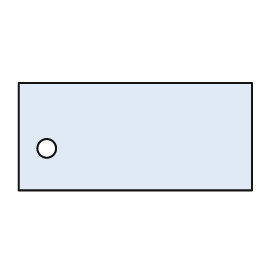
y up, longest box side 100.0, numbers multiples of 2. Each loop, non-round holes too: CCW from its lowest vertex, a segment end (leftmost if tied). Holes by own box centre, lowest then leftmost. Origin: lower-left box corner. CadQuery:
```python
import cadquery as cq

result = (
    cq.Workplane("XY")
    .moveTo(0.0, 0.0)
    .lineTo(100.0, 0.0)
    .lineTo(100.0, 46.0)
    .lineTo(0.0, 46.0)
    .close()
    .moveTo(12.0, 18.0)
    .circle(4.0)
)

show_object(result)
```